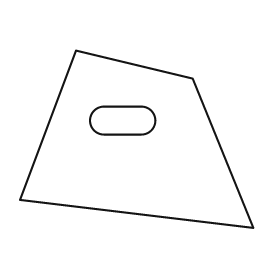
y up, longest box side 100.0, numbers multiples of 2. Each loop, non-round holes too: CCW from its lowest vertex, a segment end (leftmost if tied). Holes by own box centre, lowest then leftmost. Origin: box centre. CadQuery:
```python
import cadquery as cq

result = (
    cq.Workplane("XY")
    .moveTo(50.0, -38.0)
    .lineTo(24.0, 26.0)
    .lineTo(-26.0, 38.0)
    .lineTo(-50.0, -26.0)
    .close()
    .moveTo(-14.0, 2.0)
    .lineTo(2.0, 2.0)
    .threePointArc((8.0, 8.0), (2.0, 14.0))
    .lineTo(-14.0, 14.0)
    .threePointArc((-20.0, 8.0), (-14.0, 2.0))
    .close()
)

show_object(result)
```